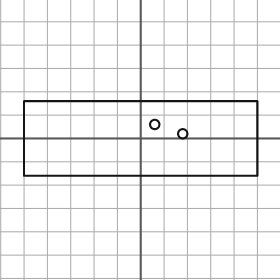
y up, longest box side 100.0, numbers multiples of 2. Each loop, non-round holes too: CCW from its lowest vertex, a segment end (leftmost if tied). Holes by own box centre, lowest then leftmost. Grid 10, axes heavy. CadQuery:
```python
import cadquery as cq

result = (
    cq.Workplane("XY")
    .moveTo(-50.0, -16.0)
    .lineTo(50.0, -16.0)
    .lineTo(50.0, 16.0)
    .lineTo(-50.0, 16.0)
    .close()
    .moveTo(18.0, 2.0)
    .circle(2.0)
    .moveTo(6.0, 6.0)
    .circle(2.0)
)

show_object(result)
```